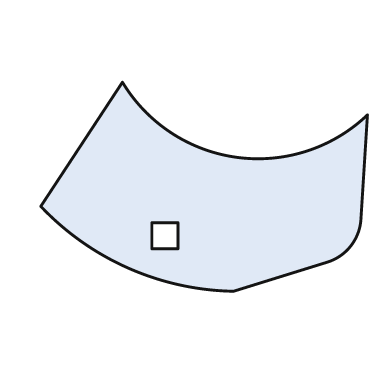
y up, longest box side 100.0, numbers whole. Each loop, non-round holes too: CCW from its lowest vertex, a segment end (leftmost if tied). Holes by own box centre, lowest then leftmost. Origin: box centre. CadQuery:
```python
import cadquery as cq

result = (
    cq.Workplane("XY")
    .moveTo(9.0, -32.0)
    .lineTo(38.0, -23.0)
    .threePointArc((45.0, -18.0), (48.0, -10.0))
    .lineTo(50.0, 22.0)
    .threePointArc((10.0, 9.0), (-25.0, 32.0))
    .lineTo(-50.0, -6.0)
    .threePointArc((-23.0, -25.0), (9.0, -32.0))
    .close()
    .moveTo(-16.0, -19.0)
    .lineTo(-8.0, -19.0)
    .lineTo(-8.0, -11.0)
    .lineTo(-16.0, -11.0)
    .close()
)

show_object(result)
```